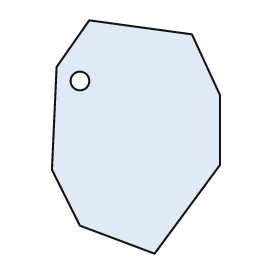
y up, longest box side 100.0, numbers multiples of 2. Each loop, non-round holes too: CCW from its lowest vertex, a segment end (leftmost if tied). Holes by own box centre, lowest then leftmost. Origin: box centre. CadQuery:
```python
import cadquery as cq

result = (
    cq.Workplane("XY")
    .moveTo(8.0, -50.0)
    .lineTo(36.0, -12.0)
    .lineTo(36.0, 18.0)
    .lineTo(24.0, 44.0)
    .lineTo(-20.0, 50.0)
    .lineTo(-34.0, 30.0)
    .lineTo(-36.0, -14.0)
    .lineTo(-24.0, -38.0)
    .close()
    .moveTo(-24.0, 24.0)
    .circle(4.0)
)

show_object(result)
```